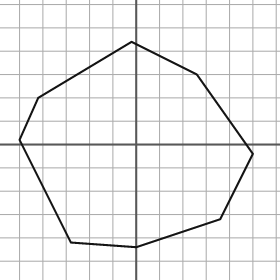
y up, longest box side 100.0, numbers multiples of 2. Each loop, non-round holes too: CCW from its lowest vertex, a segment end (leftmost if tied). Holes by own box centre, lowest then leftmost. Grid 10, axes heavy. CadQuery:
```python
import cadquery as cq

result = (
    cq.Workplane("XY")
    .moveTo(0.0, -44.0)
    .lineTo(36.0, -32.0)
    .lineTo(50.0, -4.0)
    .lineTo(26.0, 30.0)
    .lineTo(-2.0, 44.0)
    .lineTo(-42.0, 20.0)
    .lineTo(-50.0, 2.0)
    .lineTo(-28.0, -42.0)
    .close()
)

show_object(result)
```